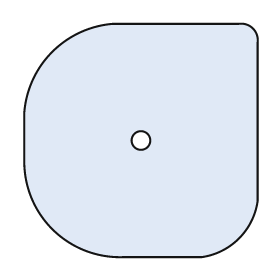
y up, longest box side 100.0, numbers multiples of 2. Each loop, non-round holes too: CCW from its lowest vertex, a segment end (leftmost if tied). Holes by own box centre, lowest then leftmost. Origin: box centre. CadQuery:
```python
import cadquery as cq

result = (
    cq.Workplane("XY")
    .moveTo(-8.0, -50.0)
    .lineTo(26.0, -50.0)
    .threePointArc((42.0, -42.0), (50.0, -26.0))
    .lineTo(50.0, 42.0)
    .threePointArc((48.0, 48.0), (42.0, 50.0))
    .lineTo(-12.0, 50.0)
    .threePointArc((-38.0, 38.0), (-50.0, 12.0))
    .lineTo(-50.0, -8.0)
    .threePointArc((-38.0, -38.0), (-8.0, -50.0))
    .close()
    .moveTo(0.0, 0.0)
    .circle(4.0)
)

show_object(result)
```